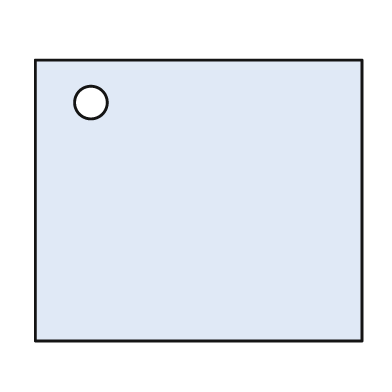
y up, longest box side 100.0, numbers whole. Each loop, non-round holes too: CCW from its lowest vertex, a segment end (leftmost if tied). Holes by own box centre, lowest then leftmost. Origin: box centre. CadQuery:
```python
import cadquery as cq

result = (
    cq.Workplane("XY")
    .moveTo(-50.0, -43.0)
    .lineTo(50.0, -43.0)
    .lineTo(50.0, 43.0)
    .lineTo(-50.0, 43.0)
    .close()
    .moveTo(-33.0, 30.0)
    .circle(5.0)
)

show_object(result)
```